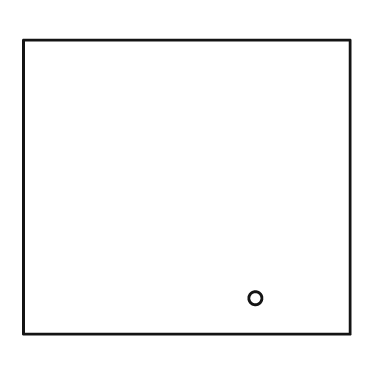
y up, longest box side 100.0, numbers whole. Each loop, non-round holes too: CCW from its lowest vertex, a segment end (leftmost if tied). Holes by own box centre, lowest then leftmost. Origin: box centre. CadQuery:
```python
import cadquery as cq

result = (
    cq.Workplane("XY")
    .moveTo(-50.0, -45.0)
    .lineTo(50.0, -45.0)
    .lineTo(50.0, 45.0)
    .lineTo(-50.0, 45.0)
    .close()
    .moveTo(21.0, -34.0)
    .circle(2.0)
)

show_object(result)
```